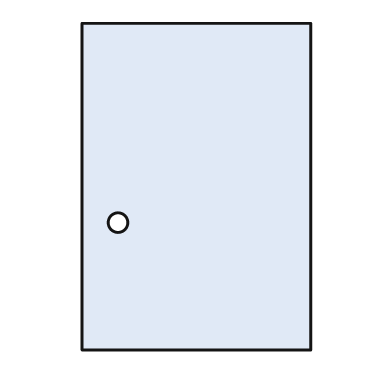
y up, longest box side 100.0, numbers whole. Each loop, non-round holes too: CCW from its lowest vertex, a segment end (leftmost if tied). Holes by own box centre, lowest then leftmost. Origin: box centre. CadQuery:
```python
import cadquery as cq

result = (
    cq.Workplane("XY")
    .moveTo(-35.0, -50.0)
    .lineTo(35.0, -50.0)
    .lineTo(35.0, 50.0)
    .lineTo(-35.0, 50.0)
    .close()
    .moveTo(-24.0, -11.0)
    .circle(3.0)
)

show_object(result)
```